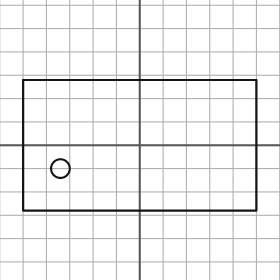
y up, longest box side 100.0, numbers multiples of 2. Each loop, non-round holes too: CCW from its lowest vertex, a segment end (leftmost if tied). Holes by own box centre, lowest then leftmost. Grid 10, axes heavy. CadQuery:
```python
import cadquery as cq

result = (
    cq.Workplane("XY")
    .moveTo(-50.0, -28.0)
    .lineTo(50.0, -28.0)
    .lineTo(50.0, 28.0)
    .lineTo(-50.0, 28.0)
    .close()
    .moveTo(-34.0, -10.0)
    .circle(4.0)
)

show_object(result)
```